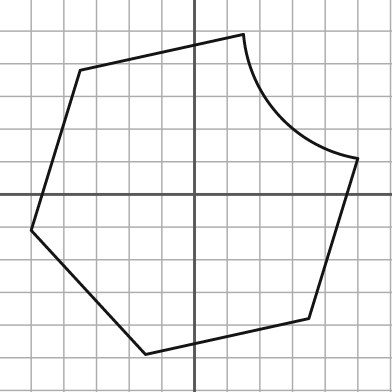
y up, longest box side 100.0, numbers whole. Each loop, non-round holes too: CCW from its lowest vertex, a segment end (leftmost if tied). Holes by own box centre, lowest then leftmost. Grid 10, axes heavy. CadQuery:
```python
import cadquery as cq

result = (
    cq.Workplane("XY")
    .moveTo(-15.0, -49.0)
    .lineTo(35.0, -38.0)
    .lineTo(50.0, 11.0)
    .threePointArc((26.0, 24.0), (15.0, 49.0))
    .lineTo(-35.0, 38.0)
    .lineTo(-50.0, -11.0)
    .close()
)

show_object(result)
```